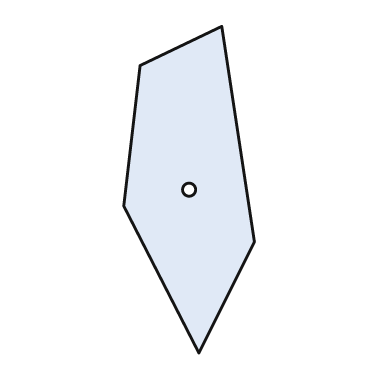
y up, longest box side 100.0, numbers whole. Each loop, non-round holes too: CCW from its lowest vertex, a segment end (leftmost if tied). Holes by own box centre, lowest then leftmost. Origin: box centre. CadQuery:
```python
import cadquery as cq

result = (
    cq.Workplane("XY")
    .moveTo(3.0, -50.0)
    .lineTo(20.0, -16.0)
    .lineTo(10.0, 50.0)
    .lineTo(-15.0, 38.0)
    .lineTo(-20.0, -5.0)
    .close()
    .moveTo(0.0, 0.0)
    .circle(2.0)
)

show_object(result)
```